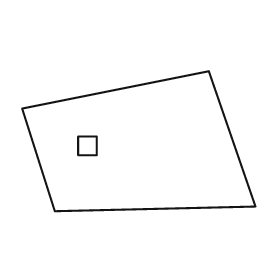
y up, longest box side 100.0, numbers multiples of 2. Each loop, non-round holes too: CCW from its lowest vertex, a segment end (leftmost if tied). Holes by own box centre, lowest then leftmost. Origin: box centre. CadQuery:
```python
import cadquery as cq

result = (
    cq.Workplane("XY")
    .moveTo(-36.0, -30.0)
    .lineTo(50.0, -28.0)
    .lineTo(30.0, 30.0)
    .lineTo(-50.0, 14.0)
    .close()
    .moveTo(-26.0, -6.0)
    .lineTo(-18.0, -6.0)
    .lineTo(-18.0, 2.0)
    .lineTo(-26.0, 2.0)
    .close()
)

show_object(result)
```